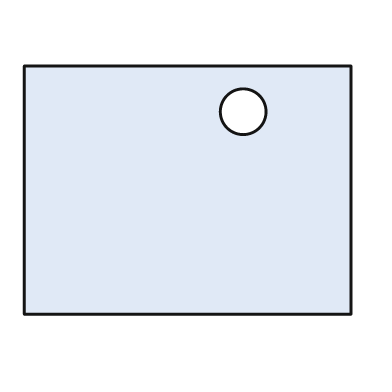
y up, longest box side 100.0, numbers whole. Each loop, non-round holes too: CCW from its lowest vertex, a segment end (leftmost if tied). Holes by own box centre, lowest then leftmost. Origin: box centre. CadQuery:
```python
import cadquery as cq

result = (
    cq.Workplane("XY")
    .moveTo(-50.0, -38.0)
    .lineTo(50.0, -38.0)
    .lineTo(50.0, 38.0)
    .lineTo(-50.0, 38.0)
    .close()
    .moveTo(17.0, 24.0)
    .circle(7.0)
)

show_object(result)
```